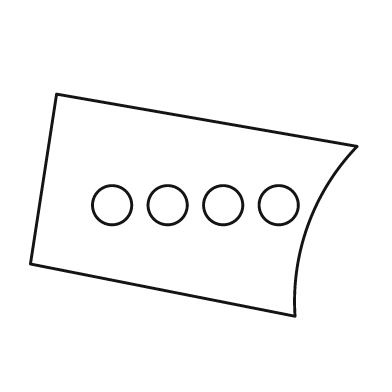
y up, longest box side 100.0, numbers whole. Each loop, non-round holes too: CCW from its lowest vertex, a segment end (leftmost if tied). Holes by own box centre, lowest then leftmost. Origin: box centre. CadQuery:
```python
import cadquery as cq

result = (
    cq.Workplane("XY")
    .moveTo(31.0, -34.0)
    .threePointArc((35.0, -6.0), (50.0, 18.0))
    .lineTo(-42.0, 34.0)
    .lineTo(-50.0, -18.0)
    .close()
    .moveTo(-25.0, 0.0)
    .circle(6.0)
    .moveTo(-8.0, 0.0)
    .circle(6.0)
    .moveTo(9.0, 0.0)
    .circle(6.0)
    .moveTo(26.0, 0.0)
    .circle(6.0)
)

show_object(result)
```